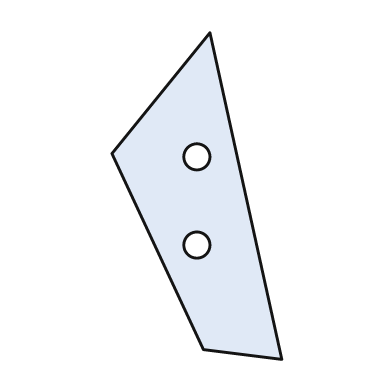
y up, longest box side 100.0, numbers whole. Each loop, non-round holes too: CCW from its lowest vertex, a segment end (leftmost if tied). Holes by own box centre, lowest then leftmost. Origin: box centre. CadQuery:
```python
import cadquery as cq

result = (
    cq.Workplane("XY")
    .moveTo(26.0, -50.0)
    .lineTo(4.0, 50.0)
    .lineTo(-26.0, 13.0)
    .lineTo(2.0, -47.0)
    .close()
    .moveTo(0.0, -15.0)
    .circle(4.0)
    .moveTo(0.0, 12.0)
    .circle(4.0)
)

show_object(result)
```